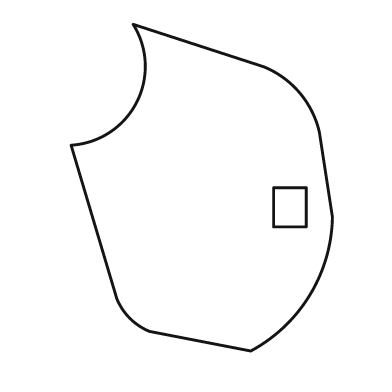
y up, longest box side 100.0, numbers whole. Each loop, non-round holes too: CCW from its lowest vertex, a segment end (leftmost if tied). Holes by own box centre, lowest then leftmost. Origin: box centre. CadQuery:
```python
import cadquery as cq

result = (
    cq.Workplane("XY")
    .moveTo(15.0, -50.0)
    .threePointArc((33.0, -33.0), (40.0, -9.0))
    .lineTo(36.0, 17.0)
    .threePointArc((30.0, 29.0), (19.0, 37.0))
    .lineTo(-21.0, 50.0)
    .threePointArc((-20.0, 26.0), (-40.0, 13.0))
    .lineTo(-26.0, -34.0)
    .threePointArc((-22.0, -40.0), (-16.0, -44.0))
    .close()
    .moveTo(22.0, -12.0)
    .lineTo(32.0, -12.0)
    .lineTo(32.0, 0.0)
    .lineTo(22.0, 0.0)
    .close()
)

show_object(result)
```